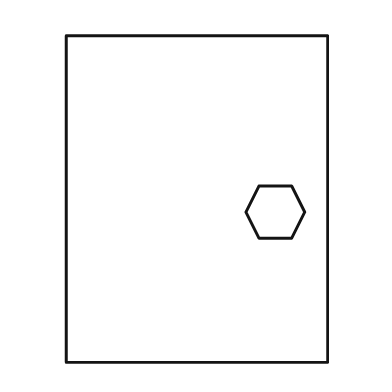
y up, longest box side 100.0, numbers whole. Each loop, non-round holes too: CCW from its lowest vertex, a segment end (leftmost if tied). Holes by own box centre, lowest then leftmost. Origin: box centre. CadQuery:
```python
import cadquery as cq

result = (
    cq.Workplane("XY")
    .moveTo(-40.0, -50.0)
    .lineTo(40.0, -50.0)
    .lineTo(40.0, 50.0)
    .lineTo(-40.0, 50.0)
    .close()
    .moveTo(19.0, -12.0)
    .lineTo(29.0, -12.0)
    .lineTo(33.0, -4.0)
    .lineTo(29.0, 4.0)
    .lineTo(19.0, 4.0)
    .lineTo(15.0, -4.0)
    .close()
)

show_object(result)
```